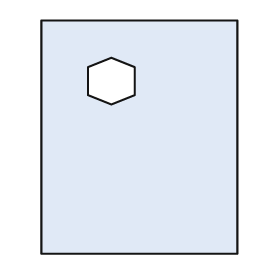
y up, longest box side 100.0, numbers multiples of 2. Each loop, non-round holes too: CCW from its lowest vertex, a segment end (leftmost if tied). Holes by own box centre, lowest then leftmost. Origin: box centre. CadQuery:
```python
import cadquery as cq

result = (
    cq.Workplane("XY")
    .moveTo(-42.0, -50.0)
    .lineTo(42.0, -50.0)
    .lineTo(42.0, 50.0)
    .lineTo(-42.0, 50.0)
    .close()
    .moveTo(-12.0, 14.0)
    .lineTo(-2.0, 18.0)
    .lineTo(-2.0, 30.0)
    .lineTo(-12.0, 34.0)
    .lineTo(-22.0, 30.0)
    .lineTo(-22.0, 18.0)
    .close()
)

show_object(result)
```